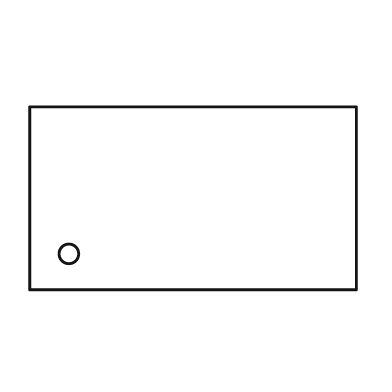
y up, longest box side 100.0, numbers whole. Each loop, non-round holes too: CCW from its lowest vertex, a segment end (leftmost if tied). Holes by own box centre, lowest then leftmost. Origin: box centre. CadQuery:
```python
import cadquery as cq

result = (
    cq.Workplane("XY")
    .moveTo(-50.0, -28.0)
    .lineTo(50.0, -28.0)
    .lineTo(50.0, 28.0)
    .lineTo(-50.0, 28.0)
    .close()
    .moveTo(-38.0, -17.0)
    .circle(3.0)
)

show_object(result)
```